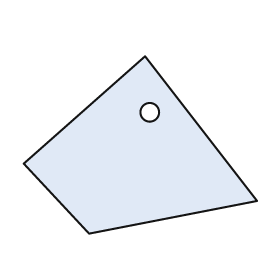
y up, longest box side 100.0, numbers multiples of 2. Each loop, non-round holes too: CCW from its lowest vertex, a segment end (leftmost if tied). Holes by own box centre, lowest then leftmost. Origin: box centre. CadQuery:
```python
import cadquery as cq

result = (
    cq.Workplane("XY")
    .moveTo(-22.0, -38.0)
    .lineTo(50.0, -24.0)
    .lineTo(2.0, 38.0)
    .lineTo(-50.0, -8.0)
    .close()
    .moveTo(4.0, 14.0)
    .circle(4.0)
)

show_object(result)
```